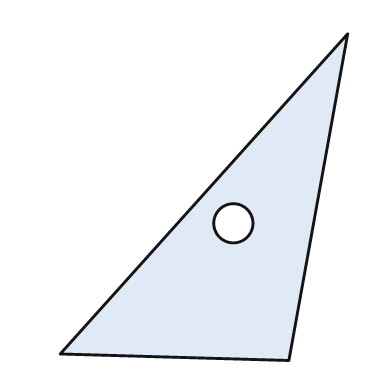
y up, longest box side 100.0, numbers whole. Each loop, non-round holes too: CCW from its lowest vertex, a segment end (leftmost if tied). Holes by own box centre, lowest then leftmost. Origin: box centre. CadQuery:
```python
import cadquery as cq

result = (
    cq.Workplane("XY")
    .moveTo(26.0, -50.0)
    .lineTo(44.0, 50.0)
    .lineTo(-44.0, -48.0)
    .close()
    .moveTo(9.0, -8.0)
    .circle(6.0)
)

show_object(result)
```